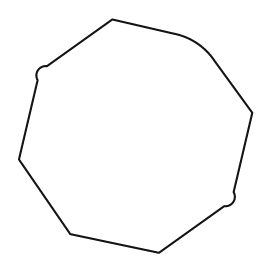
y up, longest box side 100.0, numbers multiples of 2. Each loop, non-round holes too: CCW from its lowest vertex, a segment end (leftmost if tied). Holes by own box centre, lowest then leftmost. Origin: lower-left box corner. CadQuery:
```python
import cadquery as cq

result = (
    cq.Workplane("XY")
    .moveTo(60.0, 0.0)
    .lineTo(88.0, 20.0)
    .threePointArc((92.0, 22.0), (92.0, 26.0))
    .lineTo(100.0, 60.0)
    .lineTo(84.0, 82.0)
    .threePointArc((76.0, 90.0), (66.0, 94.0))
    .lineTo(40.0, 100.0)
    .lineTo(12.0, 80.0)
    .threePointArc((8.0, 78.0), (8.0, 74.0))
    .lineTo(0.0, 40.0)
    .lineTo(22.0, 8.0)
    .close()
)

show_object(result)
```